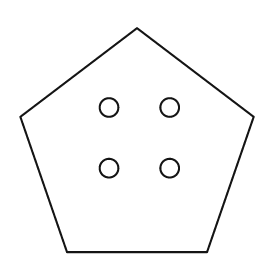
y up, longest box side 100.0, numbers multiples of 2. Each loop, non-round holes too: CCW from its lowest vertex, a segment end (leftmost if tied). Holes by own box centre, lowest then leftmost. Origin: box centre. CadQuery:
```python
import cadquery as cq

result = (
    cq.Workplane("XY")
    .moveTo(-30.0, -48.0)
    .lineTo(30.0, -48.0)
    .lineTo(50.0, 10.0)
    .lineTo(0.0, 48.0)
    .lineTo(-50.0, 10.0)
    .close()
    .moveTo(-12.0, -12.0)
    .circle(4.0)
    .moveTo(14.0, -12.0)
    .circle(4.0)
    .moveTo(-12.0, 14.0)
    .circle(4.0)
    .moveTo(14.0, 14.0)
    .circle(4.0)
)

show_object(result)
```